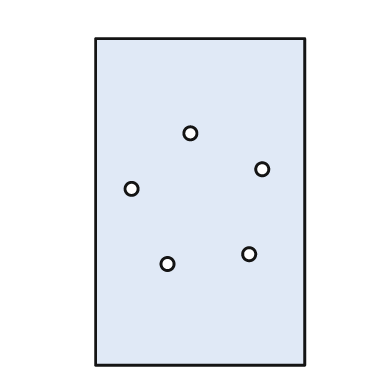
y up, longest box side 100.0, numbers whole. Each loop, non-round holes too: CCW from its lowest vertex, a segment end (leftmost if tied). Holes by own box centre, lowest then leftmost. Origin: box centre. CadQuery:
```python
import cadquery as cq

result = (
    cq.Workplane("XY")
    .moveTo(-32.0, -50.0)
    .lineTo(32.0, -50.0)
    .lineTo(32.0, 50.0)
    .lineTo(-32.0, 50.0)
    .close()
    .moveTo(-10.0, -19.0)
    .circle(2.0)
    .moveTo(15.0, -16.0)
    .circle(2.0)
    .moveTo(-21.0, 4.0)
    .circle(2.0)
    .moveTo(19.0, 10.0)
    .circle(2.0)
    .moveTo(-3.0, 21.0)
    .circle(2.0)
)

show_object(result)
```